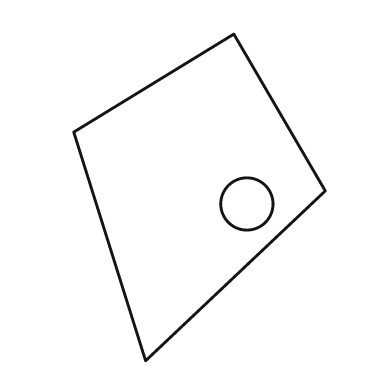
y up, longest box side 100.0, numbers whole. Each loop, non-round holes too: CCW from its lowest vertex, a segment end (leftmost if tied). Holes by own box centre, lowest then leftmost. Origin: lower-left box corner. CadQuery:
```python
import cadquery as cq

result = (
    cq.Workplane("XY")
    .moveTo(22.0, 0.0)
    .lineTo(77.0, 52.0)
    .lineTo(49.0, 100.0)
    .lineTo(0.0, 70.0)
    .close()
    .moveTo(53.0, 48.0)
    .circle(8.0)
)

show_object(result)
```